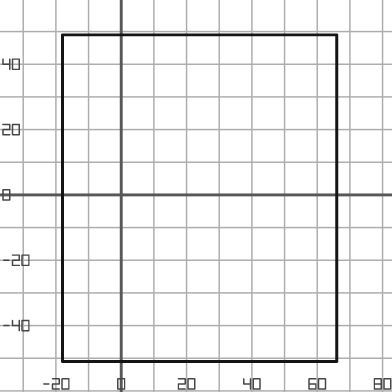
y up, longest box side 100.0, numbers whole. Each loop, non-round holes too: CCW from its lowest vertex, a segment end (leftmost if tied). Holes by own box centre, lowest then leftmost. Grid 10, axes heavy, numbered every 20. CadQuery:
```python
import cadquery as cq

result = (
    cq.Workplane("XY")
    .moveTo(-18.0, -51.0)
    .lineTo(66.0, -51.0)
    .lineTo(66.0, 49.0)
    .lineTo(-18.0, 49.0)
    .close()
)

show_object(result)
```